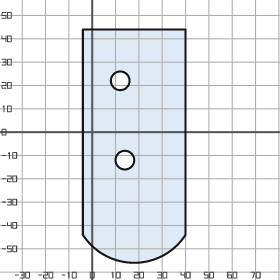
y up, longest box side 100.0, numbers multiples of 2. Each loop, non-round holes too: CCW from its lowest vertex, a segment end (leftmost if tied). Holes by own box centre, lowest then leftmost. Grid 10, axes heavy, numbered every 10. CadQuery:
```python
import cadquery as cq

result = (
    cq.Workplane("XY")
    .moveTo(-4.0, -44.0)
    .threePointArc((18.0, -56.0), (40.0, -44.0))
    .lineTo(40.0, 44.0)
    .lineTo(-4.0, 44.0)
    .close()
    .moveTo(14.0, -12.0)
    .circle(4.0)
    .moveTo(12.0, 22.0)
    .circle(4.0)
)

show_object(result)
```